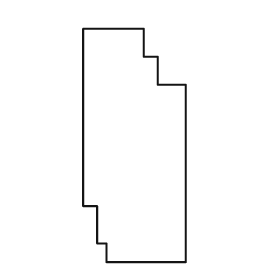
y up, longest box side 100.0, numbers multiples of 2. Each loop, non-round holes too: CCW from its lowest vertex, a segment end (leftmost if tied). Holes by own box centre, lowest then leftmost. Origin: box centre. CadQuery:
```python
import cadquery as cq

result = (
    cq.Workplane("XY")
    .moveTo(-12.0, -50.0)
    .lineTo(22.0, -50.0)
    .lineTo(22.0, 26.0)
    .lineTo(10.0, 26.0)
    .lineTo(10.0, 38.0)
    .lineTo(4.0, 38.0)
    .lineTo(4.0, 50.0)
    .lineTo(-22.0, 50.0)
    .lineTo(-22.0, -26.0)
    .lineTo(-16.0, -26.0)
    .lineTo(-16.0, -42.0)
    .lineTo(-12.0, -42.0)
    .close()
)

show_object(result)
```